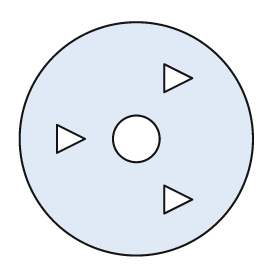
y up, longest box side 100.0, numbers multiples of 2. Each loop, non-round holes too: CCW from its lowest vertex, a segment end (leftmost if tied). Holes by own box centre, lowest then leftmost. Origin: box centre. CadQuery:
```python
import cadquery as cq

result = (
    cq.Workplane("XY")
    .moveTo(0.0, 0.0)
    .circle(50.0)
    .moveTo(12.0, -32.0)
    .lineTo(24.0, -26.0)
    .lineTo(12.0, -20.0)
    .close()
    .moveTo(-34.0, -6.0)
    .lineTo(-22.0, 0.0)
    .lineTo(-34.0, 6.0)
    .close()
    .moveTo(0.0, 0.0)
    .circle(10.0)
    .moveTo(12.0, 20.0)
    .lineTo(24.0, 26.0)
    .lineTo(12.0, 32.0)
    .close()
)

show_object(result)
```